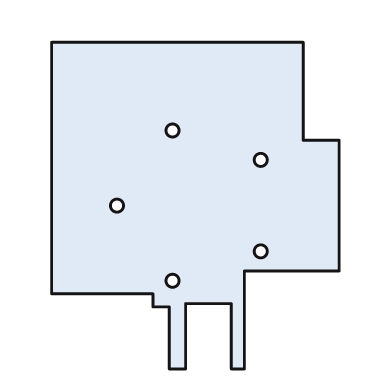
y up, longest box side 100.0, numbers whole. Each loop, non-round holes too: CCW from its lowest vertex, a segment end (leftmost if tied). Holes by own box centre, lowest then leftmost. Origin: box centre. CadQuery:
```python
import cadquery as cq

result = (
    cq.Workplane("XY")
    .moveTo(-8.0, -50.0)
    .lineTo(-3.0, -50.0)
    .lineTo(-3.0, -30.0)
    .lineTo(11.0, -30.0)
    .lineTo(11.0, -50.0)
    .lineTo(15.0, -50.0)
    .lineTo(15.0, -20.0)
    .lineTo(44.0, -20.0)
    .lineTo(44.0, 20.0)
    .lineTo(33.0, 20.0)
    .lineTo(33.0, 50.0)
    .lineTo(-44.0, 50.0)
    .lineTo(-44.0, -27.0)
    .lineTo(-13.0, -27.0)
    .lineTo(-13.0, -31.0)
    .lineTo(-8.0, -31.0)
    .close()
    .moveTo(-7.0, -23.0)
    .circle(2.0)
    .moveTo(20.0, -14.0)
    .circle(2.0)
    .moveTo(-24.0, 0.0)
    .circle(2.0)
    .moveTo(20.0, 14.0)
    .circle(2.0)
    .moveTo(-7.0, 23.0)
    .circle(2.0)
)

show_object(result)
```